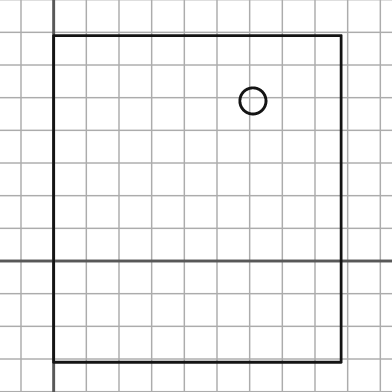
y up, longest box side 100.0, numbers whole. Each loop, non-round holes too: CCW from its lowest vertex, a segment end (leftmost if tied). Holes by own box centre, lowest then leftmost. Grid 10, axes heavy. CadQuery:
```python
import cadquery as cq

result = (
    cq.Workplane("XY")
    .moveTo(0.0, -31.0)
    .lineTo(88.0, -31.0)
    .lineTo(88.0, 69.0)
    .lineTo(0.0, 69.0)
    .close()
    .moveTo(61.0, 49.0)
    .circle(4.0)
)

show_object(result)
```